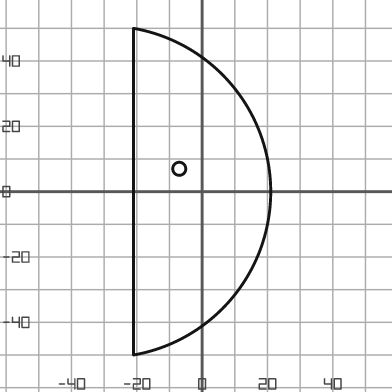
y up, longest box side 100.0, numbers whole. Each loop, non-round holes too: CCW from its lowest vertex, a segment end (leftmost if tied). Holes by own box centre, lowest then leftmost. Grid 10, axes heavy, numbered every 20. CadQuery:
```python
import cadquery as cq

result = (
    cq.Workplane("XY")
    .moveTo(-21.0, -50.0)
    .threePointArc((21.0, 0.0), (-21.0, 50.0))
    .close()
    .moveTo(-7.0, 7.0)
    .circle(2.0)
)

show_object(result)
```